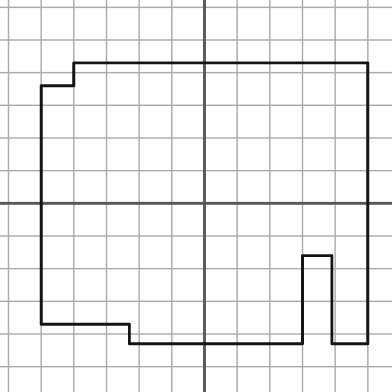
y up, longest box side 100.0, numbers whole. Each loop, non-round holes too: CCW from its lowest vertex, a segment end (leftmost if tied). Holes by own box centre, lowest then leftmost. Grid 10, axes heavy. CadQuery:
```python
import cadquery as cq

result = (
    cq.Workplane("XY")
    .moveTo(-23.0, -43.0)
    .lineTo(30.0, -43.0)
    .lineTo(30.0, -16.0)
    .lineTo(39.0, -16.0)
    .lineTo(39.0, -43.0)
    .lineTo(50.0, -43.0)
    .lineTo(50.0, 43.0)
    .lineTo(-40.0, 43.0)
    .lineTo(-40.0, 36.0)
    .lineTo(-50.0, 36.0)
    .lineTo(-50.0, -37.0)
    .lineTo(-23.0, -37.0)
    .close()
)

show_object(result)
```